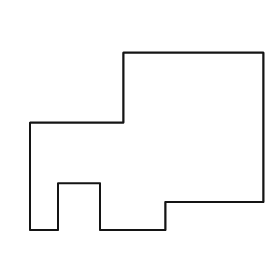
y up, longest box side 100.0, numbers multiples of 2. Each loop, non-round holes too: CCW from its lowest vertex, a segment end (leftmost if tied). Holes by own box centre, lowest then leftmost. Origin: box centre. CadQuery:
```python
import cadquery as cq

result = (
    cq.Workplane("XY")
    .moveTo(-50.0, -38.0)
    .lineTo(-38.0, -38.0)
    .lineTo(-38.0, -18.0)
    .lineTo(-20.0, -18.0)
    .lineTo(-20.0, -38.0)
    .lineTo(8.0, -38.0)
    .lineTo(8.0, -26.0)
    .lineTo(50.0, -26.0)
    .lineTo(50.0, 38.0)
    .lineTo(-10.0, 38.0)
    .lineTo(-10.0, 8.0)
    .lineTo(-50.0, 8.0)
    .close()
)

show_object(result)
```